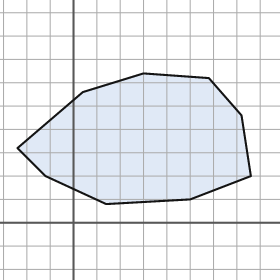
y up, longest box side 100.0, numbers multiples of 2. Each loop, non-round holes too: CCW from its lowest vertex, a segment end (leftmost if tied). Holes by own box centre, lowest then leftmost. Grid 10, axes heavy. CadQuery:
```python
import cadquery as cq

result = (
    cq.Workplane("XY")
    .moveTo(14.0, 8.0)
    .lineTo(50.0, 10.0)
    .lineTo(76.0, 20.0)
    .lineTo(72.0, 46.0)
    .lineTo(58.0, 62.0)
    .lineTo(30.0, 64.0)
    .lineTo(4.0, 56.0)
    .lineTo(-24.0, 32.0)
    .lineTo(-12.0, 20.0)
    .close()
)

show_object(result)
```